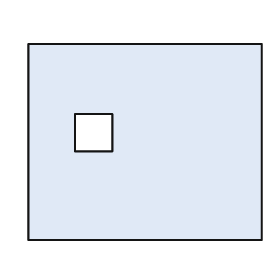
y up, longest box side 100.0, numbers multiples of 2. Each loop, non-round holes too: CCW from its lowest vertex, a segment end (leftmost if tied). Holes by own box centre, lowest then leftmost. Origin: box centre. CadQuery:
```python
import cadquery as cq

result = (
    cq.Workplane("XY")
    .moveTo(-50.0, -42.0)
    .lineTo(50.0, -42.0)
    .lineTo(50.0, 42.0)
    .lineTo(-50.0, 42.0)
    .close()
    .moveTo(-30.0, -4.0)
    .lineTo(-14.0, -4.0)
    .lineTo(-14.0, 12.0)
    .lineTo(-30.0, 12.0)
    .close()
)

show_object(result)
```